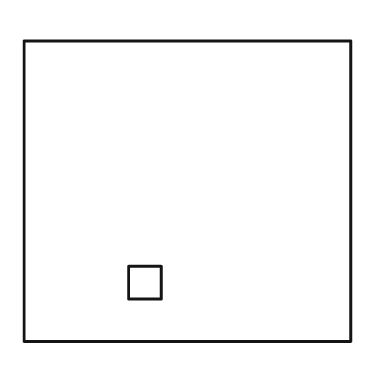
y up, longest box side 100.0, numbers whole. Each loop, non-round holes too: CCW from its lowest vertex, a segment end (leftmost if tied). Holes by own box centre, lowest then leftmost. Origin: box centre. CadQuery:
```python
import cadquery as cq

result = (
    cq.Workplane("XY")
    .moveTo(-50.0, -46.0)
    .lineTo(50.0, -46.0)
    .lineTo(50.0, 46.0)
    .lineTo(-50.0, 46.0)
    .close()
    .moveTo(-18.0, -33.0)
    .lineTo(-8.0, -33.0)
    .lineTo(-8.0, -23.0)
    .lineTo(-18.0, -23.0)
    .close()
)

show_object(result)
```